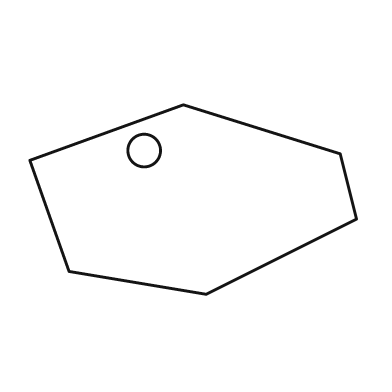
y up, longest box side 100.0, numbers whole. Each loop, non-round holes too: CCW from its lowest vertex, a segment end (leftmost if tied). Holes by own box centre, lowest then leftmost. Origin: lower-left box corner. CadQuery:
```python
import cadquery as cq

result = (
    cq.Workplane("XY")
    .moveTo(54.0, 0.0)
    .lineTo(100.0, 23.0)
    .lineTo(95.0, 43.0)
    .lineTo(47.0, 58.0)
    .lineTo(0.0, 41.0)
    .lineTo(12.0, 7.0)
    .close()
    .moveTo(35.0, 44.0)
    .circle(5.0)
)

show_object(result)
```